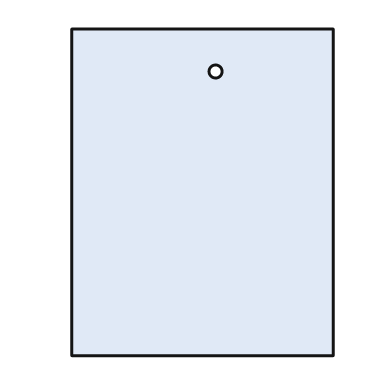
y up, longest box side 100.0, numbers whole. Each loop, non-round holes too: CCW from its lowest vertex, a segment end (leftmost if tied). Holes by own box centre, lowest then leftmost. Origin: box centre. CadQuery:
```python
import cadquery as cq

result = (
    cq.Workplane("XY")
    .moveTo(-40.0, -50.0)
    .lineTo(40.0, -50.0)
    .lineTo(40.0, 50.0)
    .lineTo(-40.0, 50.0)
    .close()
    .moveTo(4.0, 37.0)
    .circle(2.0)
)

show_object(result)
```